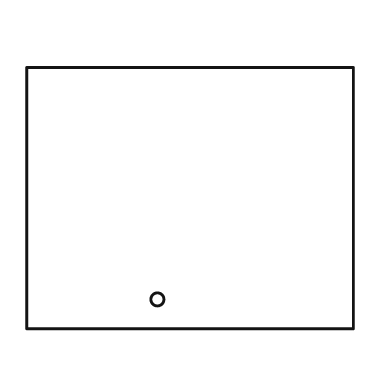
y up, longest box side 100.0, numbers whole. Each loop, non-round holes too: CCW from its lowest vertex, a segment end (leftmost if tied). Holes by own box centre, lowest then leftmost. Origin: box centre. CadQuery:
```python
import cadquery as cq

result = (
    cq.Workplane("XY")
    .moveTo(-50.0, -40.0)
    .lineTo(50.0, -40.0)
    .lineTo(50.0, 40.0)
    .lineTo(-50.0, 40.0)
    .close()
    .moveTo(-10.0, -31.0)
    .circle(2.0)
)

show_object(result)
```